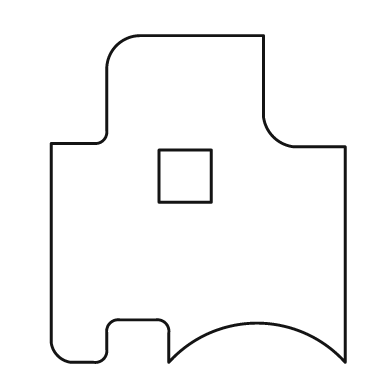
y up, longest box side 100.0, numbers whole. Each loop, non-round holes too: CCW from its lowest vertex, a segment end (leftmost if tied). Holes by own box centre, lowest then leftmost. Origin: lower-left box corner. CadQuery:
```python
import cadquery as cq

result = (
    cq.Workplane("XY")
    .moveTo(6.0, 0.0)
    .lineTo(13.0, 0.0)
    .threePointArc((16.0, 1.0), (17.0, 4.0))
    .lineTo(17.0, 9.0)
    .threePointArc((18.0, 12.0), (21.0, 13.0))
    .lineTo(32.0, 13.0)
    .threePointArc((35.0, 12.0), (36.0, 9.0))
    .lineTo(36.0, 0.0)
    .threePointArc((63.0, 12.0), (90.0, 0.0))
    .lineTo(90.0, 66.0)
    .lineTo(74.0, 66.0)
    .threePointArc((68.0, 69.0), (65.0, 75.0))
    .lineTo(65.0, 100.0)
    .lineTo(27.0, 100.0)
    .threePointArc((20.0, 97.0), (17.0, 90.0))
    .lineTo(17.0, 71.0)
    .threePointArc((16.0, 68.0), (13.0, 67.0))
    .lineTo(0.0, 67.0)
    .lineTo(0.0, 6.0)
    .threePointArc((2.0, 2.0), (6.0, 0.0))
    .close()
    .moveTo(33.0, 49.0)
    .lineTo(49.0, 49.0)
    .lineTo(49.0, 65.0)
    .lineTo(33.0, 65.0)
    .close()
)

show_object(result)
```